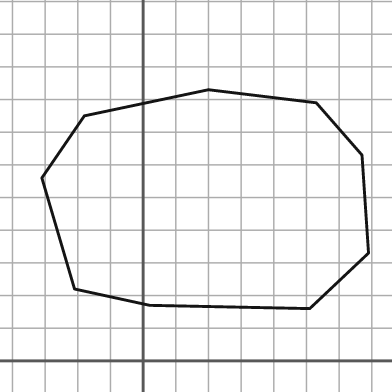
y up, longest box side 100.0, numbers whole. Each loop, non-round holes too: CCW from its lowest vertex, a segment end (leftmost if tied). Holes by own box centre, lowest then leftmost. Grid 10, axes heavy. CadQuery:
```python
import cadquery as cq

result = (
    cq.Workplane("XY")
    .moveTo(51.0, 16.0)
    .lineTo(69.0, 33.0)
    .lineTo(67.0, 63.0)
    .lineTo(53.0, 79.0)
    .lineTo(20.0, 83.0)
    .lineTo(-18.0, 75.0)
    .lineTo(-31.0, 56.0)
    .lineTo(-21.0, 22.0)
    .lineTo(2.0, 17.0)
    .close()
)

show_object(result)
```